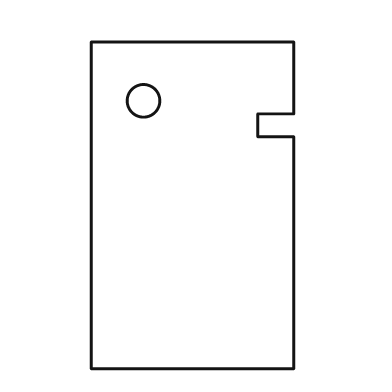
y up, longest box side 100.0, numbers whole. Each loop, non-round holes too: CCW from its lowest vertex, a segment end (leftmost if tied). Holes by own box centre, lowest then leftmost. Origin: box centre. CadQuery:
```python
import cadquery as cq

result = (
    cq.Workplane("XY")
    .moveTo(-31.0, -50.0)
    .lineTo(31.0, -50.0)
    .lineTo(31.0, 21.0)
    .lineTo(20.0, 21.0)
    .lineTo(20.0, 28.0)
    .lineTo(31.0, 28.0)
    .lineTo(31.0, 50.0)
    .lineTo(-31.0, 50.0)
    .close()
    .moveTo(-15.0, 32.0)
    .circle(5.0)
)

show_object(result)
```